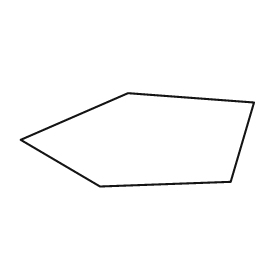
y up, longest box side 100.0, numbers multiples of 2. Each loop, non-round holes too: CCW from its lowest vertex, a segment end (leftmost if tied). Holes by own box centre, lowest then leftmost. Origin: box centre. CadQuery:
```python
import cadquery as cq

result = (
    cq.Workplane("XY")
    .moveTo(-16.0, -20.0)
    .lineTo(40.0, -18.0)
    .lineTo(50.0, 16.0)
    .lineTo(-4.0, 20.0)
    .lineTo(-50.0, 0.0)
    .close()
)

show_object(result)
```